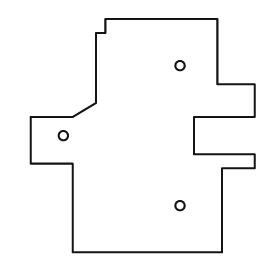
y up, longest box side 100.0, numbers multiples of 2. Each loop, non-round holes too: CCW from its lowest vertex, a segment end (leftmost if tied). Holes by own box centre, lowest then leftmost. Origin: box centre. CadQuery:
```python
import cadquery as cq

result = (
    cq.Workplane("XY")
    .moveTo(-30.0, -50.0)
    .lineTo(34.0, -50.0)
    .lineTo(34.0, -14.0)
    .lineTo(48.0, -14.0)
    .lineTo(48.0, -8.0)
    .lineTo(22.0, -8.0)
    .lineTo(22.0, 8.0)
    .lineTo(48.0, 8.0)
    .lineTo(48.0, 22.0)
    .lineTo(32.0, 22.0)
    .lineTo(32.0, 50.0)
    .lineTo(-16.0, 50.0)
    .lineTo(-16.0, 44.0)
    .lineTo(-20.0, 44.0)
    .lineTo(-20.0, 14.0)
    .lineTo(-30.0, 8.0)
    .lineTo(-48.0, 8.0)
    .lineTo(-48.0, -12.0)
    .lineTo(-30.0, -12.0)
    .close()
    .moveTo(16.0, -30.0)
    .circle(2.0)
    .moveTo(-34.0, 0.0)
    .circle(2.0)
    .moveTo(16.0, 30.0)
    .circle(2.0)
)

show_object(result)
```